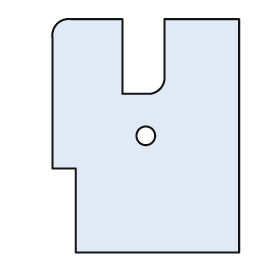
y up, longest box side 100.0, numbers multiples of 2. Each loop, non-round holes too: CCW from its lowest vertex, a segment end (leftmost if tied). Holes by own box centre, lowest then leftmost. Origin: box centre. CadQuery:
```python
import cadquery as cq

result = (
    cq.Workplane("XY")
    .moveTo(-30.0, -50.0)
    .lineTo(40.0, -50.0)
    .lineTo(40.0, 50.0)
    .lineTo(8.0, 50.0)
    .lineTo(8.0, 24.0)
    .threePointArc((6.0, 20.0), (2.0, 18.0))
    .lineTo(-10.0, 18.0)
    .lineTo(-10.0, 50.0)
    .lineTo(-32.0, 50.0)
    .threePointArc((-38.0, 48.0), (-40.0, 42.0))
    .lineTo(-40.0, -14.0)
    .lineTo(-30.0, -14.0)
    .close()
    .moveTo(0.0, 0.0)
    .circle(4.0)
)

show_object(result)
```